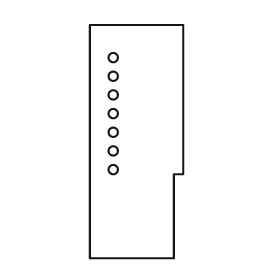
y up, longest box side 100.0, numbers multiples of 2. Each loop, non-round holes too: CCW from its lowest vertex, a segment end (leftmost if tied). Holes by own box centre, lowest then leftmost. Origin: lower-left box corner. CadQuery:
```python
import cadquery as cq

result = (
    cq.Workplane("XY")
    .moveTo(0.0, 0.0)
    .lineTo(36.0, 0.0)
    .lineTo(36.0, 36.0)
    .lineTo(40.0, 36.0)
    .lineTo(40.0, 100.0)
    .lineTo(0.0, 100.0)
    .close()
    .moveTo(10.0, 38.0)
    .circle(2.0)
    .moveTo(10.0, 46.0)
    .circle(2.0)
    .moveTo(10.0, 54.0)
    .circle(2.0)
    .moveTo(10.0, 62.0)
    .circle(2.0)
    .moveTo(10.0, 70.0)
    .circle(2.0)
    .moveTo(10.0, 78.0)
    .circle(2.0)
    .moveTo(10.0, 86.0)
    .circle(2.0)
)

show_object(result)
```